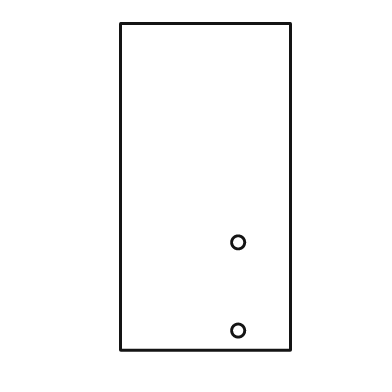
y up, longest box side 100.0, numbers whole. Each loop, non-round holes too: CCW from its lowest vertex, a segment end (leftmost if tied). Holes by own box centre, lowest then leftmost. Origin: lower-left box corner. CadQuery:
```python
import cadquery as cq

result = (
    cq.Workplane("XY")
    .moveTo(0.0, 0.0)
    .lineTo(52.0, 0.0)
    .lineTo(52.0, 100.0)
    .lineTo(0.0, 100.0)
    .close()
    .moveTo(36.0, 6.0)
    .circle(2.0)
    .moveTo(36.0, 33.0)
    .circle(2.0)
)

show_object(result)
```